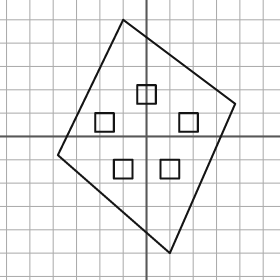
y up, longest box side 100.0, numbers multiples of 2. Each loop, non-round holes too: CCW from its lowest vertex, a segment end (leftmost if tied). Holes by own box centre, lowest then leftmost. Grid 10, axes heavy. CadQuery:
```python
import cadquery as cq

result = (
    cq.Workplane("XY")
    .moveTo(10.0, -50.0)
    .lineTo(38.0, 14.0)
    .lineTo(-10.0, 50.0)
    .lineTo(-38.0, -8.0)
    .close()
    .moveTo(-14.0, -18.0)
    .lineTo(-6.0, -18.0)
    .lineTo(-6.0, -10.0)
    .lineTo(-14.0, -10.0)
    .close()
    .moveTo(6.0, -18.0)
    .lineTo(14.0, -18.0)
    .lineTo(14.0, -10.0)
    .lineTo(6.0, -10.0)
    .close()
    .moveTo(-22.0, 2.0)
    .lineTo(-14.0, 2.0)
    .lineTo(-14.0, 10.0)
    .lineTo(-22.0, 10.0)
    .close()
    .moveTo(14.0, 2.0)
    .lineTo(22.0, 2.0)
    .lineTo(22.0, 10.0)
    .lineTo(14.0, 10.0)
    .close()
    .moveTo(-4.0, 14.0)
    .lineTo(4.0, 14.0)
    .lineTo(4.0, 22.0)
    .lineTo(-4.0, 22.0)
    .close()
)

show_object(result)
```